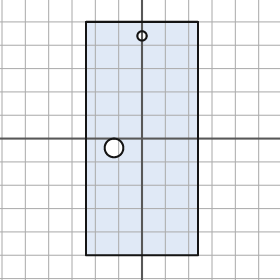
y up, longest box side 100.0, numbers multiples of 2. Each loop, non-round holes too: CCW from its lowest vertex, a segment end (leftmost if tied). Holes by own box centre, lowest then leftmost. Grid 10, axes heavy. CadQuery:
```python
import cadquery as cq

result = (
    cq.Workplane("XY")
    .moveTo(-24.0, -50.0)
    .lineTo(24.0, -50.0)
    .lineTo(24.0, 50.0)
    .lineTo(-24.0, 50.0)
    .close()
    .moveTo(-12.0, -4.0)
    .circle(4.0)
    .moveTo(0.0, 44.0)
    .circle(2.0)
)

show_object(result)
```